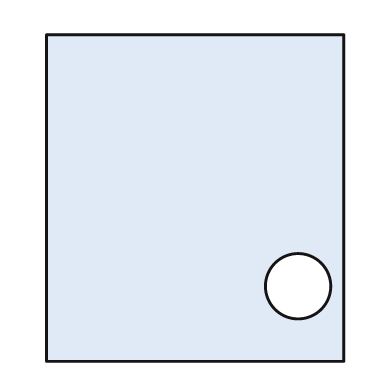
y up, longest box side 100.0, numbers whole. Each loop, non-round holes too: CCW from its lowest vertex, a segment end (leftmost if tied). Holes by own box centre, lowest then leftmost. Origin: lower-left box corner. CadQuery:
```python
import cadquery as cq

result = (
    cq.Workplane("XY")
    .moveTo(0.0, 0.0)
    .lineTo(91.0, 0.0)
    .lineTo(91.0, 100.0)
    .lineTo(0.0, 100.0)
    .close()
    .moveTo(77.0, 23.0)
    .circle(10.0)
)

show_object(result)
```